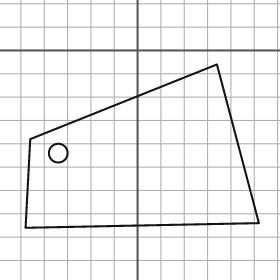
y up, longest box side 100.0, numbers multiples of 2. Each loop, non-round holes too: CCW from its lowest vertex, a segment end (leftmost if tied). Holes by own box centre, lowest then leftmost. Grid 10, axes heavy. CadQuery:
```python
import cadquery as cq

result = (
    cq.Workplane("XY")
    .moveTo(-48.0, -76.0)
    .lineTo(52.0, -74.0)
    .lineTo(34.0, -6.0)
    .lineTo(-46.0, -38.0)
    .close()
    .moveTo(-34.0, -44.0)
    .circle(4.0)
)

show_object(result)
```